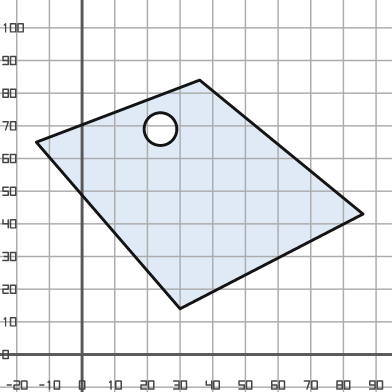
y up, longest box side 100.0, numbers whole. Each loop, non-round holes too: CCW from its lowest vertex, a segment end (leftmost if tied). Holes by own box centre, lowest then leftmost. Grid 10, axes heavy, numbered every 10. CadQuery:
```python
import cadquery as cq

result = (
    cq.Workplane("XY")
    .moveTo(30.0, 14.0)
    .lineTo(86.0, 43.0)
    .lineTo(36.0, 84.0)
    .lineTo(-14.0, 65.0)
    .close()
    .moveTo(24.0, 69.0)
    .circle(5.0)
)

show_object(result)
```